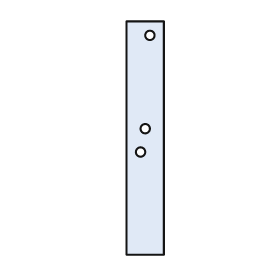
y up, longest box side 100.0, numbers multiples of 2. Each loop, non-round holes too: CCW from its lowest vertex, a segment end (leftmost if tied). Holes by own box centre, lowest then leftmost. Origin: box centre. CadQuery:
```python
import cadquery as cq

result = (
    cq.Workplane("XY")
    .moveTo(-8.0, -50.0)
    .lineTo(8.0, -50.0)
    .lineTo(8.0, 50.0)
    .lineTo(-8.0, 50.0)
    .close()
    .moveTo(-2.0, -6.0)
    .circle(2.0)
    .moveTo(0.0, 4.0)
    .circle(2.0)
    .moveTo(2.0, 44.0)
    .circle(2.0)
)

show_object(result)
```